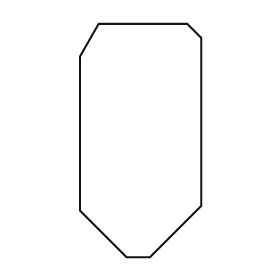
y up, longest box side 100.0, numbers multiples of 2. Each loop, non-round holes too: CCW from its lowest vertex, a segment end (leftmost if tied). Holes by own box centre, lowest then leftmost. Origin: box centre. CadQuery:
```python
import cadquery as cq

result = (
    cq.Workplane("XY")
    .moveTo(-6.0, -50.0)
    .lineTo(4.0, -50.0)
    .lineTo(26.0, -28.0)
    .lineTo(26.0, 44.0)
    .lineTo(20.0, 50.0)
    .lineTo(-18.0, 50.0)
    .lineTo(-26.0, 36.0)
    .lineTo(-26.0, -30.0)
    .close()
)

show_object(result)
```